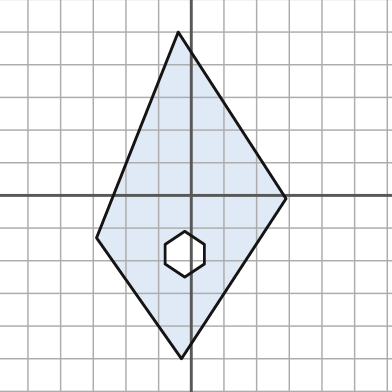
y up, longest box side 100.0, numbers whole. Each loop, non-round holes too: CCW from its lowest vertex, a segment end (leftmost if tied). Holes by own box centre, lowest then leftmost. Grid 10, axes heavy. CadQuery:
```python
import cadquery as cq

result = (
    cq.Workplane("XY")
    .moveTo(-3.0, -50.0)
    .lineTo(29.0, -1.0)
    .lineTo(-4.0, 50.0)
    .lineTo(-29.0, -13.0)
    .close()
    .moveTo(-2.0, -25.0)
    .lineTo(4.0, -21.0)
    .lineTo(4.0, -15.0)
    .lineTo(-2.0, -11.0)
    .lineTo(-8.0, -15.0)
    .lineTo(-8.0, -21.0)
    .close()
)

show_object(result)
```